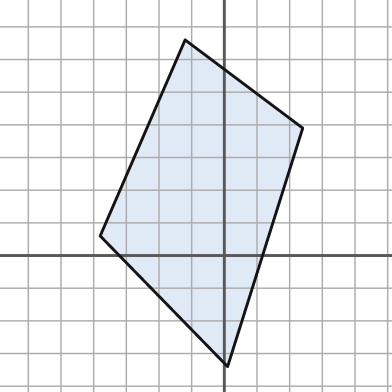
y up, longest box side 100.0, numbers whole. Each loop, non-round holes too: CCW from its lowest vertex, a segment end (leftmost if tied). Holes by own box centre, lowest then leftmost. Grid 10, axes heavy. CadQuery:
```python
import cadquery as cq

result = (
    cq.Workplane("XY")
    .moveTo(1.0, -34.0)
    .lineTo(24.0, 39.0)
    .lineTo(-12.0, 66.0)
    .lineTo(-38.0, 6.0)
    .close()
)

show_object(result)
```